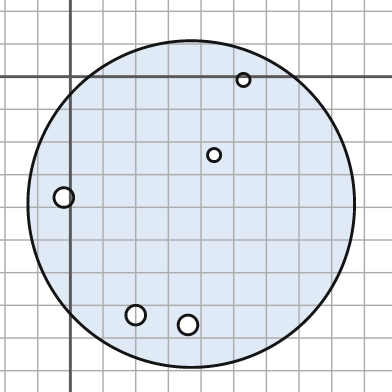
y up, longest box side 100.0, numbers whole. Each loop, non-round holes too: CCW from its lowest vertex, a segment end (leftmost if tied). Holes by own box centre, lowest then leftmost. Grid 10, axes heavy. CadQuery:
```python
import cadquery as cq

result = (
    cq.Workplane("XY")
    .moveTo(37.0, -39.0)
    .circle(50.0)
    .moveTo(36.0, -76.0)
    .circle(3.0)
    .moveTo(20.0, -73.0)
    .circle(3.0)
    .moveTo(-2.0, -37.0)
    .circle(3.0)
    .moveTo(44.0, -24.0)
    .circle(2.0)
    .moveTo(53.0, -1.0)
    .circle(2.0)
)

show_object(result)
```